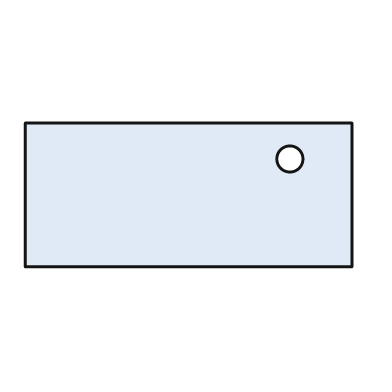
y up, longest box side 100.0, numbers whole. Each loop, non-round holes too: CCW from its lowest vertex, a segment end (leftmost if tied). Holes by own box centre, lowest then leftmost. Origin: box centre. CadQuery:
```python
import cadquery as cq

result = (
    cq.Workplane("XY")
    .moveTo(-50.0, -22.0)
    .lineTo(50.0, -22.0)
    .lineTo(50.0, 22.0)
    .lineTo(-50.0, 22.0)
    .close()
    .moveTo(31.0, 11.0)
    .circle(4.0)
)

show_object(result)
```